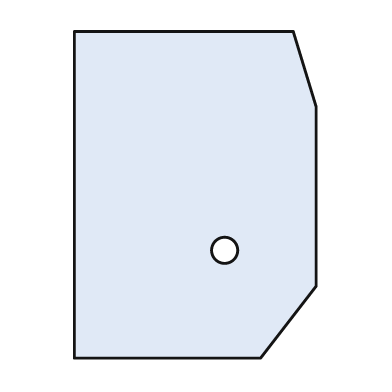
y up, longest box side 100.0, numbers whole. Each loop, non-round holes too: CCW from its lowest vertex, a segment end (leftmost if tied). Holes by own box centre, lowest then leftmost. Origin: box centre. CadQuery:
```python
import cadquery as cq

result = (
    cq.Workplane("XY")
    .moveTo(-37.0, -50.0)
    .lineTo(20.0, -50.0)
    .lineTo(37.0, -28.0)
    .lineTo(37.0, 27.0)
    .lineTo(30.0, 50.0)
    .lineTo(-37.0, 50.0)
    .close()
    .moveTo(9.0, -17.0)
    .circle(4.0)
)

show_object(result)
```